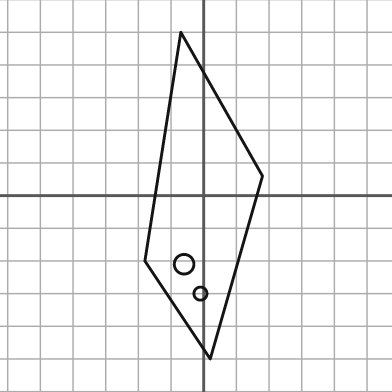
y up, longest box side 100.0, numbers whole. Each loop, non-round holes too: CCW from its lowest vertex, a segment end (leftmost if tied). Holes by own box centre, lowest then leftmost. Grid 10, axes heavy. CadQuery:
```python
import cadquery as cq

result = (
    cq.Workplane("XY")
    .moveTo(2.0, -50.0)
    .lineTo(18.0, 6.0)
    .lineTo(-7.0, 50.0)
    .lineTo(-18.0, -20.0)
    .close()
    .moveTo(-1.0, -30.0)
    .circle(2.0)
    .moveTo(-6.0, -21.0)
    .circle(3.0)
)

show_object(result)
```